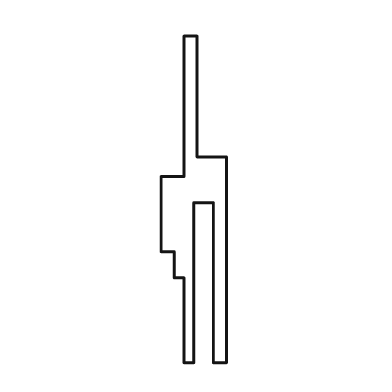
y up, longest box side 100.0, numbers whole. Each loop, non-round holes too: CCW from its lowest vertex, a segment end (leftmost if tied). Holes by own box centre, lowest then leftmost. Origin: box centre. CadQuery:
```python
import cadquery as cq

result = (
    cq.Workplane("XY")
    .moveTo(-3.0, -50.0)
    .lineTo(0.0, -50.0)
    .lineTo(0.0, -1.0)
    .lineTo(6.0, -1.0)
    .lineTo(6.0, -50.0)
    .lineTo(10.0, -50.0)
    .lineTo(10.0, 13.0)
    .lineTo(1.0, 13.0)
    .lineTo(1.0, 50.0)
    .lineTo(-3.0, 50.0)
    .lineTo(-3.0, 7.0)
    .lineTo(-10.0, 7.0)
    .lineTo(-10.0, -16.0)
    .lineTo(-6.0, -16.0)
    .lineTo(-6.0, -24.0)
    .lineTo(-3.0, -24.0)
    .close()
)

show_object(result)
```